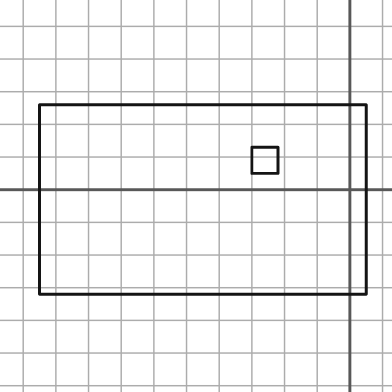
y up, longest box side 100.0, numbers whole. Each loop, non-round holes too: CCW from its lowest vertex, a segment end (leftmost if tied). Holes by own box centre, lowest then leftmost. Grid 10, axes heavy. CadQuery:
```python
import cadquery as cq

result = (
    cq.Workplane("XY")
    .moveTo(-95.0, -32.0)
    .lineTo(5.0, -32.0)
    .lineTo(5.0, 26.0)
    .lineTo(-95.0, 26.0)
    .close()
    .moveTo(-30.0, 5.0)
    .lineTo(-22.0, 5.0)
    .lineTo(-22.0, 13.0)
    .lineTo(-30.0, 13.0)
    .close()
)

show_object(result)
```